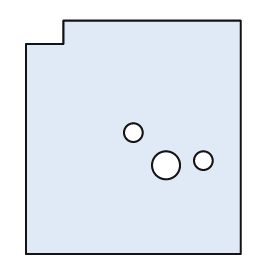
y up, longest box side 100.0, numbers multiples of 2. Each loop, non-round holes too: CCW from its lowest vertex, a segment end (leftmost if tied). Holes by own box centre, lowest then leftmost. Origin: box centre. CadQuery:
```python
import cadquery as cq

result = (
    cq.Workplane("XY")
    .moveTo(-46.0, -50.0)
    .lineTo(46.0, -50.0)
    .lineTo(46.0, 50.0)
    .lineTo(-30.0, 50.0)
    .lineTo(-30.0, 40.0)
    .lineTo(-46.0, 40.0)
    .close()
    .moveTo(14.0, -12.0)
    .circle(6.0)
    .moveTo(30.0, -10.0)
    .circle(4.0)
    .moveTo(0.0, 2.0)
    .circle(4.0)
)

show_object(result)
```